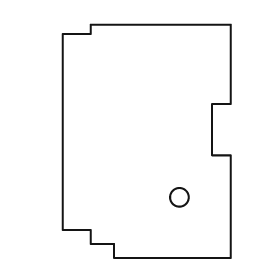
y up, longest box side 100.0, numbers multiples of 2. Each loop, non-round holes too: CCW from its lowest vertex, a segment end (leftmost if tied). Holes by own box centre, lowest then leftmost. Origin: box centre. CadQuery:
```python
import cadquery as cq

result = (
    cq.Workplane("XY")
    .moveTo(-14.0, -50.0)
    .lineTo(36.0, -50.0)
    .lineTo(36.0, -6.0)
    .lineTo(28.0, -6.0)
    .lineTo(28.0, 16.0)
    .lineTo(36.0, 16.0)
    .lineTo(36.0, 50.0)
    .lineTo(-24.0, 50.0)
    .lineTo(-24.0, 46.0)
    .lineTo(-36.0, 46.0)
    .lineTo(-36.0, -38.0)
    .lineTo(-24.0, -38.0)
    .lineTo(-24.0, -44.0)
    .lineTo(-14.0, -44.0)
    .close()
    .moveTo(14.0, -24.0)
    .circle(4.0)
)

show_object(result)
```